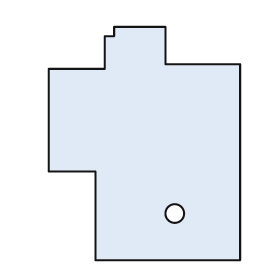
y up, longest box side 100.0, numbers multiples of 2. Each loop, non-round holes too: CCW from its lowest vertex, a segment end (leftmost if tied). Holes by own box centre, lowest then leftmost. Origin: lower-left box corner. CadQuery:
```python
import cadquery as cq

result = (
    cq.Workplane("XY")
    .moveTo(20.0, 0.0)
    .lineTo(82.0, 0.0)
    .lineTo(82.0, 84.0)
    .lineTo(50.0, 84.0)
    .lineTo(50.0, 100.0)
    .lineTo(28.0, 100.0)
    .lineTo(28.0, 96.0)
    .lineTo(24.0, 96.0)
    .lineTo(24.0, 82.0)
    .lineTo(0.0, 82.0)
    .lineTo(0.0, 38.0)
    .lineTo(20.0, 38.0)
    .close()
    .moveTo(54.0, 20.0)
    .circle(4.0)
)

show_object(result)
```